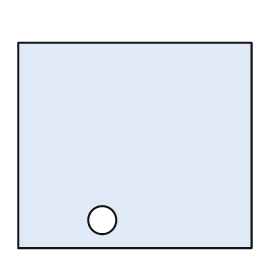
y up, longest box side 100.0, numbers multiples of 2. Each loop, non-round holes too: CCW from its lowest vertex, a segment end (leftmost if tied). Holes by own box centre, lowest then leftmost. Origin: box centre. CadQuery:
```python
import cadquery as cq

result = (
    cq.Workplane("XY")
    .moveTo(-50.0, -44.0)
    .lineTo(50.0, -44.0)
    .lineTo(50.0, 44.0)
    .lineTo(-50.0, 44.0)
    .close()
    .moveTo(-14.0, -32.0)
    .circle(6.0)
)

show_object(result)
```